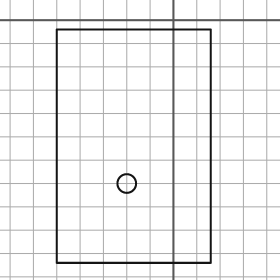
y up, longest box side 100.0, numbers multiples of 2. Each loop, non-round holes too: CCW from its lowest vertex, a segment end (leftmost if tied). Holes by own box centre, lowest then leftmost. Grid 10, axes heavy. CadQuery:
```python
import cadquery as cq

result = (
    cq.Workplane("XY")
    .moveTo(-50.0, -104.0)
    .lineTo(16.0, -104.0)
    .lineTo(16.0, -4.0)
    .lineTo(-50.0, -4.0)
    .close()
    .moveTo(-20.0, -70.0)
    .circle(4.0)
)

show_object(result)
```